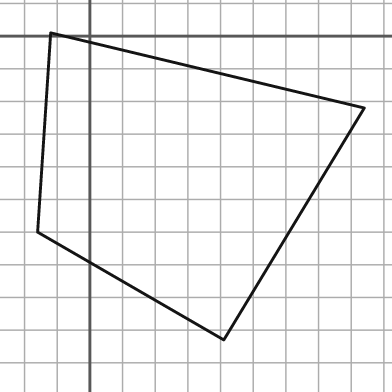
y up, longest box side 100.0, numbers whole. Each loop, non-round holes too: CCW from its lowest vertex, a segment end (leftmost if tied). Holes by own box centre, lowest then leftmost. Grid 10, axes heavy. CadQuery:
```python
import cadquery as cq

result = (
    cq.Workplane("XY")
    .moveTo(41.0, -93.0)
    .lineTo(84.0, -22.0)
    .lineTo(-12.0, 1.0)
    .lineTo(-16.0, -60.0)
    .close()
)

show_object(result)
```